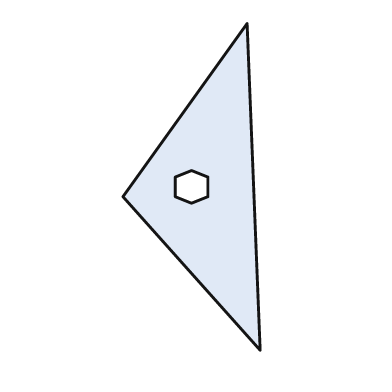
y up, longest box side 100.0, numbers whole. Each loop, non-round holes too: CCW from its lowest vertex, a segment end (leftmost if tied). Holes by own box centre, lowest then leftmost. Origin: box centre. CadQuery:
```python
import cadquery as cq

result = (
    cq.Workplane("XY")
    .moveTo(21.0, -50.0)
    .lineTo(17.0, 50.0)
    .lineTo(-21.0, -3.0)
    .close()
    .moveTo(0.0, -5.0)
    .lineTo(5.0, -3.0)
    .lineTo(5.0, 3.0)
    .lineTo(0.0, 5.0)
    .lineTo(-5.0, 3.0)
    .lineTo(-5.0, -3.0)
    .close()
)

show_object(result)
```